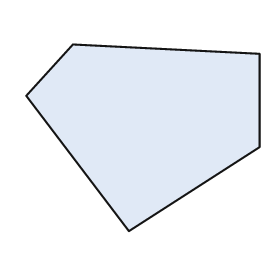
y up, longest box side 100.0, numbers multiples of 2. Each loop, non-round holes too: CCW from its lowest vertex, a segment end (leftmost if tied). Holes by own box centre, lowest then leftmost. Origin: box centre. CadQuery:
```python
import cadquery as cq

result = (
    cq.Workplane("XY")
    .moveTo(-6.0, -40.0)
    .lineTo(50.0, -4.0)
    .lineTo(50.0, 36.0)
    .lineTo(-30.0, 40.0)
    .lineTo(-50.0, 18.0)
    .close()
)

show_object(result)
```